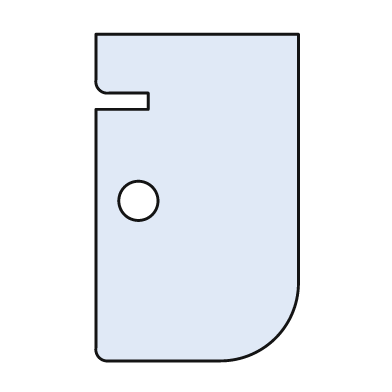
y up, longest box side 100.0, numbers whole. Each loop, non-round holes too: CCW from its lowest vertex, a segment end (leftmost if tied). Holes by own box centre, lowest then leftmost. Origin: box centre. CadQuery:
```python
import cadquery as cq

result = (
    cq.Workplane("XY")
    .moveTo(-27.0, -50.0)
    .lineTo(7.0, -50.0)
    .threePointArc((24.0, -43.0), (31.0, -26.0))
    .lineTo(31.0, 50.0)
    .lineTo(-31.0, 50.0)
    .lineTo(-31.0, 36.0)
    .threePointArc((-30.0, 33.0), (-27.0, 32.0))
    .lineTo(-15.0, 32.0)
    .lineTo(-15.0, 27.0)
    .lineTo(-31.0, 27.0)
    .lineTo(-31.0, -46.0)
    .threePointArc((-30.0, -49.0), (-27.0, -50.0))
    .close()
    .moveTo(-18.0, -1.0)
    .circle(6.0)
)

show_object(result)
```